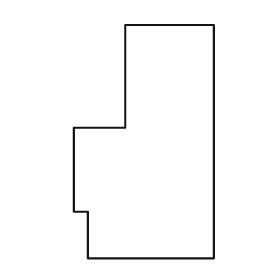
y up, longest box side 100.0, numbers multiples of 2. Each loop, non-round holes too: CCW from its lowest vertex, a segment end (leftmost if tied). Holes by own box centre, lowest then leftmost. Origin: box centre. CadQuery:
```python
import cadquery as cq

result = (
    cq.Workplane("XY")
    .moveTo(-24.0, -50.0)
    .lineTo(30.0, -50.0)
    .lineTo(30.0, 50.0)
    .lineTo(-8.0, 50.0)
    .lineTo(-8.0, 6.0)
    .lineTo(-30.0, 6.0)
    .lineTo(-30.0, -30.0)
    .lineTo(-24.0, -30.0)
    .close()
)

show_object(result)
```